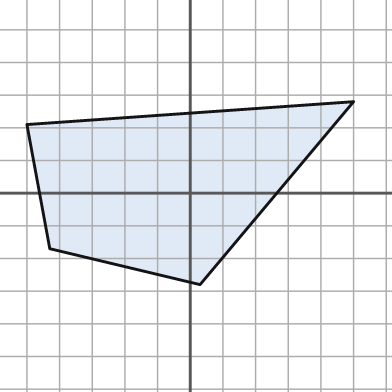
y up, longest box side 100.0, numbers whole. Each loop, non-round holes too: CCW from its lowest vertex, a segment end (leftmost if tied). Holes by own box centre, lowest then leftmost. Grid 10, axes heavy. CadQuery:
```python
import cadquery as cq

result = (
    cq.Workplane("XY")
    .moveTo(3.0, -28.0)
    .lineTo(50.0, 28.0)
    .lineTo(-50.0, 21.0)
    .lineTo(-43.0, -17.0)
    .close()
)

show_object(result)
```